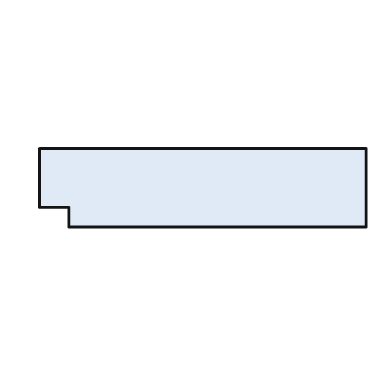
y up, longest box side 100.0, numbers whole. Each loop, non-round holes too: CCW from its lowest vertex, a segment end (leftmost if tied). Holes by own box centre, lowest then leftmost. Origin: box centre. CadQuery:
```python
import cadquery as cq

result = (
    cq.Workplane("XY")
    .moveTo(-41.0, -12.0)
    .lineTo(50.0, -12.0)
    .lineTo(50.0, 12.0)
    .lineTo(-50.0, 12.0)
    .lineTo(-50.0, -6.0)
    .lineTo(-41.0, -6.0)
    .close()
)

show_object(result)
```